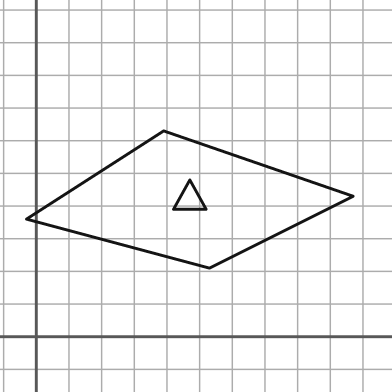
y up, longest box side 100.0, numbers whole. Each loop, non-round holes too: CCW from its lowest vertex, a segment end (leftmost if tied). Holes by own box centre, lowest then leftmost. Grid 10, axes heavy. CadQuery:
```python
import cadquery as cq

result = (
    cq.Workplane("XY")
    .moveTo(53.0, 21.0)
    .lineTo(97.0, 43.0)
    .lineTo(39.0, 63.0)
    .lineTo(-3.0, 36.0)
    .close()
    .moveTo(42.0, 39.0)
    .lineTo(52.0, 39.0)
    .lineTo(47.0, 48.0)
    .close()
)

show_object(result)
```